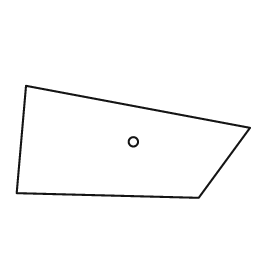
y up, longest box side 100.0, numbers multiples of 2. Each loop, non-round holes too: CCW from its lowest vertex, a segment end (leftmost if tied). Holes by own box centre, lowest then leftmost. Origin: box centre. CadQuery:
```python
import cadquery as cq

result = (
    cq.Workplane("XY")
    .moveTo(28.0, -24.0)
    .lineTo(50.0, 6.0)
    .lineTo(-46.0, 24.0)
    .lineTo(-50.0, -22.0)
    .close()
    .moveTo(0.0, 0.0)
    .circle(2.0)
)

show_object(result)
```